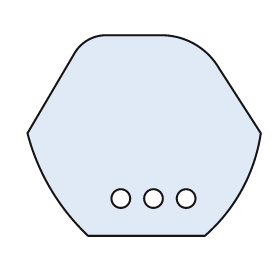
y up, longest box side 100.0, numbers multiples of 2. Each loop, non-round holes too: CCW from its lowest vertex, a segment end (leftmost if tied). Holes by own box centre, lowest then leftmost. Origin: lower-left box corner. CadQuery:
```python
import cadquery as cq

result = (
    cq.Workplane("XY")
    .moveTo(26.0, 0.0)
    .lineTo(76.0, 0.0)
    .threePointArc((92.0, 20.0), (100.0, 44.0))
    .lineTo(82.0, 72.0)
    .threePointArc((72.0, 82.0), (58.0, 86.0))
    .lineTo(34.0, 86.0)
    .threePointArc((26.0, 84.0), (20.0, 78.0))
    .lineTo(0.0, 44.0)
    .threePointArc((10.0, 20.0), (26.0, 0.0))
    .close()
    .moveTo(40.0, 16.0)
    .circle(4.0)
    .moveTo(54.0, 16.0)
    .circle(4.0)
    .moveTo(68.0, 16.0)
    .circle(4.0)
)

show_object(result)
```